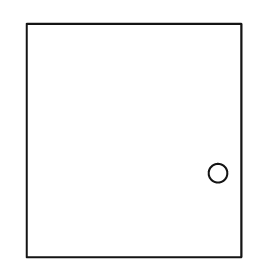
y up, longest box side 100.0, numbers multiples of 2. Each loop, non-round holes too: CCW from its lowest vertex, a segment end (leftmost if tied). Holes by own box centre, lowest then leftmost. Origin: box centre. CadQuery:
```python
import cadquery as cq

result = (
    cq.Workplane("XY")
    .moveTo(-46.0, -50.0)
    .lineTo(46.0, -50.0)
    .lineTo(46.0, 50.0)
    .lineTo(-46.0, 50.0)
    .close()
    .moveTo(36.0, -14.0)
    .circle(4.0)
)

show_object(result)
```